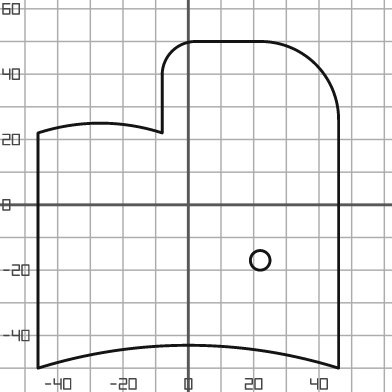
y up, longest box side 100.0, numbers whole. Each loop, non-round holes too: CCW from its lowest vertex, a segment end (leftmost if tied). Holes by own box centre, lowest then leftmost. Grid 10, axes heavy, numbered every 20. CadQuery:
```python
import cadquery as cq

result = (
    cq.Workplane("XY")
    .moveTo(-46.0, -50.0)
    .threePointArc((0.0, -43.0), (46.0, -50.0))
    .lineTo(46.0, 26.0)
    .threePointArc((39.0, 43.0), (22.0, 50.0))
    .lineTo(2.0, 50.0)
    .threePointArc((-5.0, 47.0), (-8.0, 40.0))
    .lineTo(-8.0, 22.0)
    .threePointArc((-27.0, 25.0), (-46.0, 22.0))
    .close()
    .moveTo(22.0, -17.0)
    .circle(3.0)
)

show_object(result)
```